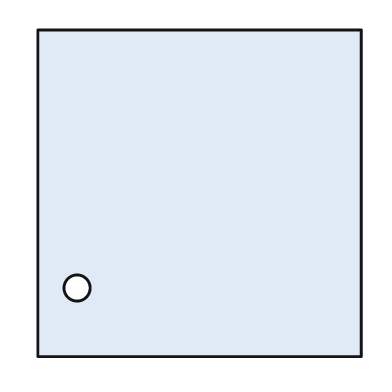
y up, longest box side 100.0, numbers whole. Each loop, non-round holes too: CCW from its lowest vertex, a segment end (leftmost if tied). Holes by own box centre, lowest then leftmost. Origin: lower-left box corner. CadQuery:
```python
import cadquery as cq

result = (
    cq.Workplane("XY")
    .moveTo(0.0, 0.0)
    .lineTo(99.0, 0.0)
    .lineTo(99.0, 100.0)
    .lineTo(0.0, 100.0)
    .close()
    .moveTo(12.0, 21.0)
    .circle(4.0)
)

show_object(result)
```